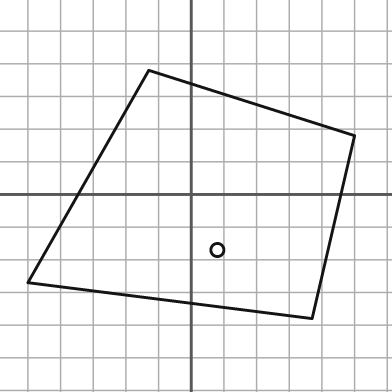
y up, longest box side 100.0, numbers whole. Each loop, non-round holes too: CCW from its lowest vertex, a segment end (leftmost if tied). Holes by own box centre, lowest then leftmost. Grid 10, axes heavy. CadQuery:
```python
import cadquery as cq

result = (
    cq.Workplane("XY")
    .moveTo(37.0, -38.0)
    .lineTo(50.0, 18.0)
    .lineTo(-13.0, 38.0)
    .lineTo(-50.0, -27.0)
    .close()
    .moveTo(8.0, -17.0)
    .circle(2.0)
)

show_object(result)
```